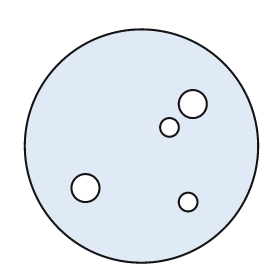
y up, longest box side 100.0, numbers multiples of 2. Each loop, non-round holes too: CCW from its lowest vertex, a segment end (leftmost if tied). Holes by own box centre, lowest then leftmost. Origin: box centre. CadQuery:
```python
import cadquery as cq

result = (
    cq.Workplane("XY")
    .moveTo(0.0, 0.0)
    .circle(50.0)
    .moveTo(20.0, -24.0)
    .circle(4.0)
    .moveTo(-24.0, -18.0)
    .circle(6.0)
    .moveTo(12.0, 8.0)
    .circle(4.0)
    .moveTo(22.0, 18.0)
    .circle(6.0)
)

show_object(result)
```